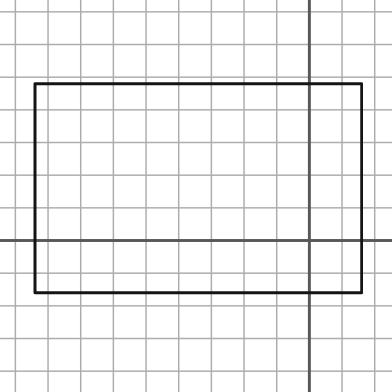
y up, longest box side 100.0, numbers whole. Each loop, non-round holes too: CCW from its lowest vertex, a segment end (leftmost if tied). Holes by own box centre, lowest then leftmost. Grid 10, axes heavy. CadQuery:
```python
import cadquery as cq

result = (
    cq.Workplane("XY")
    .moveTo(-84.0, -16.0)
    .lineTo(16.0, -16.0)
    .lineTo(16.0, 48.0)
    .lineTo(-84.0, 48.0)
    .close()
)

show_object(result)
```